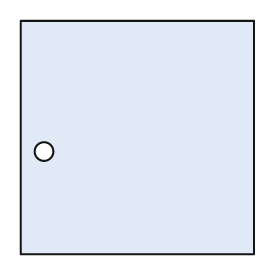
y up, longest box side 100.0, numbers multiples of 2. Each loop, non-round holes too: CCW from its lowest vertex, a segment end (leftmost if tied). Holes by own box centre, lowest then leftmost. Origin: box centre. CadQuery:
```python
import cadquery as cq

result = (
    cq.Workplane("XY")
    .moveTo(-50.0, -50.0)
    .lineTo(50.0, -50.0)
    .lineTo(50.0, 50.0)
    .lineTo(-50.0, 50.0)
    .close()
    .moveTo(-40.0, -6.0)
    .circle(4.0)
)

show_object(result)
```